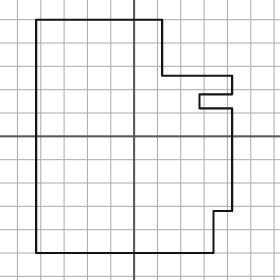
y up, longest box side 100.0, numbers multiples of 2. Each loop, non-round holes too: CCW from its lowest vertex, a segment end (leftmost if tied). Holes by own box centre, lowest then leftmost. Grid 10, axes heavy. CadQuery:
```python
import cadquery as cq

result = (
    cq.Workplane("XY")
    .moveTo(-42.0, -50.0)
    .lineTo(34.0, -50.0)
    .lineTo(34.0, -32.0)
    .lineTo(42.0, -32.0)
    .lineTo(42.0, 12.0)
    .lineTo(28.0, 12.0)
    .lineTo(28.0, 18.0)
    .lineTo(42.0, 18.0)
    .lineTo(42.0, 26.0)
    .lineTo(12.0, 26.0)
    .lineTo(12.0, 50.0)
    .lineTo(-42.0, 50.0)
    .close()
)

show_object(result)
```